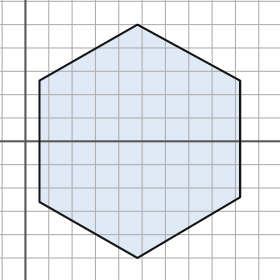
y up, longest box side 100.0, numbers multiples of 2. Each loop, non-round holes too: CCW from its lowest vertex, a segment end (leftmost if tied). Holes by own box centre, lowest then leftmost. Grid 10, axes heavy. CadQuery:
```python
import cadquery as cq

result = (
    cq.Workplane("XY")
    .moveTo(48.0, -50.0)
    .lineTo(92.0, -24.0)
    .lineTo(92.0, 26.0)
    .lineTo(48.0, 50.0)
    .lineTo(6.0, 26.0)
    .lineTo(6.0, -26.0)
    .close()
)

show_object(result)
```